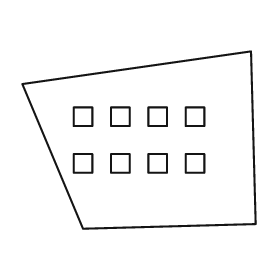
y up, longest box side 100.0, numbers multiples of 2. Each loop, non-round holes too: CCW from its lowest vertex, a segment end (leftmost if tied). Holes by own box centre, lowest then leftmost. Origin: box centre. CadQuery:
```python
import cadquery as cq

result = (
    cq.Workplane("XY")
    .moveTo(-24.0, -38.0)
    .lineTo(50.0, -36.0)
    .lineTo(48.0, 38.0)
    .lineTo(-50.0, 24.0)
    .close()
    .moveTo(-28.0, -14.0)
    .lineTo(-20.0, -14.0)
    .lineTo(-20.0, -6.0)
    .lineTo(-28.0, -6.0)
    .close()
    .moveTo(-12.0, -14.0)
    .lineTo(-4.0, -14.0)
    .lineTo(-4.0, -6.0)
    .lineTo(-12.0, -6.0)
    .close()
    .moveTo(4.0, -14.0)
    .lineTo(12.0, -14.0)
    .lineTo(12.0, -6.0)
    .lineTo(4.0, -6.0)
    .close()
    .moveTo(20.0, -14.0)
    .lineTo(28.0, -14.0)
    .lineTo(28.0, -6.0)
    .lineTo(20.0, -6.0)
    .close()
    .moveTo(-28.0, 6.0)
    .lineTo(-20.0, 6.0)
    .lineTo(-20.0, 14.0)
    .lineTo(-28.0, 14.0)
    .close()
    .moveTo(-12.0, 6.0)
    .lineTo(-4.0, 6.0)
    .lineTo(-4.0, 14.0)
    .lineTo(-12.0, 14.0)
    .close()
    .moveTo(4.0, 6.0)
    .lineTo(12.0, 6.0)
    .lineTo(12.0, 14.0)
    .lineTo(4.0, 14.0)
    .close()
    .moveTo(20.0, 6.0)
    .lineTo(28.0, 6.0)
    .lineTo(28.0, 14.0)
    .lineTo(20.0, 14.0)
    .close()
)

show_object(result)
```